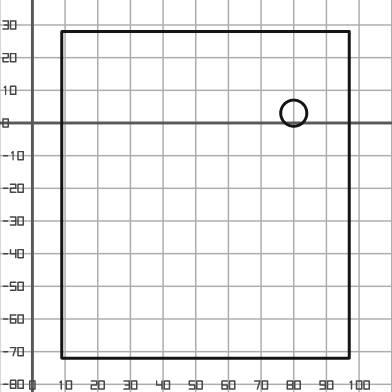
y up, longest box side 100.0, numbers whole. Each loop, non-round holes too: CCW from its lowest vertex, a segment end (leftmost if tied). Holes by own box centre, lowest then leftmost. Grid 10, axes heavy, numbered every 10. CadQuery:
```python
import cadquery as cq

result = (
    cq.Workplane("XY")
    .moveTo(9.0, -72.0)
    .lineTo(97.0, -72.0)
    .lineTo(97.0, 28.0)
    .lineTo(9.0, 28.0)
    .close()
    .moveTo(80.0, 3.0)
    .circle(4.0)
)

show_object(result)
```